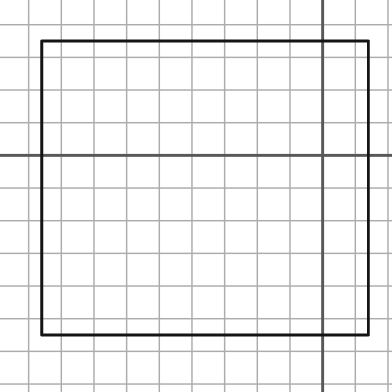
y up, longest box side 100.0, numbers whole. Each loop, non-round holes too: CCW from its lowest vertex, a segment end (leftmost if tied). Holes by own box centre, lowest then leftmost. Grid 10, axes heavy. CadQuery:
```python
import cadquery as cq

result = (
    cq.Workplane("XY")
    .moveTo(-86.0, -55.0)
    .lineTo(14.0, -55.0)
    .lineTo(14.0, 35.0)
    .lineTo(-86.0, 35.0)
    .close()
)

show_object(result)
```